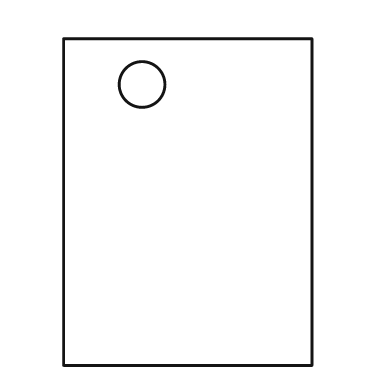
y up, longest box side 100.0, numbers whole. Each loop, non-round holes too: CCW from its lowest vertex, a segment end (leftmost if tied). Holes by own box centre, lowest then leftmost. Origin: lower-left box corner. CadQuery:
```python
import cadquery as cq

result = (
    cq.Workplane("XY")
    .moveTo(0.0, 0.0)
    .lineTo(76.0, 0.0)
    .lineTo(76.0, 100.0)
    .lineTo(0.0, 100.0)
    .close()
    .moveTo(24.0, 86.0)
    .circle(7.0)
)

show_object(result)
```